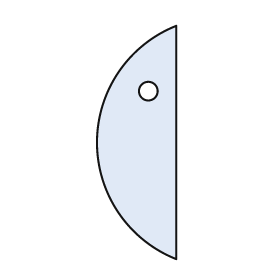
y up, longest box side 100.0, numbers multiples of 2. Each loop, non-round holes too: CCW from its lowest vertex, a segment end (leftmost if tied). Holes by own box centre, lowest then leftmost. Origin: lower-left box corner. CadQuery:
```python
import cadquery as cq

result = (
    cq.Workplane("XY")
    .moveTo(34.0, 0.0)
    .lineTo(34.0, 100.0)
    .threePointArc((0.0, 50.0), (34.0, 0.0))
    .close()
    .moveTo(22.0, 72.0)
    .circle(4.0)
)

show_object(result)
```